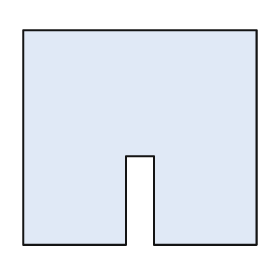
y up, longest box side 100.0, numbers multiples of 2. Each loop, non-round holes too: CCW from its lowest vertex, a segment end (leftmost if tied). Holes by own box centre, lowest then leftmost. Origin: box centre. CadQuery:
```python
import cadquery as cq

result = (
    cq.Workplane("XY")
    .moveTo(-50.0, -46.0)
    .lineTo(-6.0, -46.0)
    .lineTo(-6.0, -8.0)
    .lineTo(6.0, -8.0)
    .lineTo(6.0, -46.0)
    .lineTo(50.0, -46.0)
    .lineTo(50.0, 46.0)
    .lineTo(-50.0, 46.0)
    .close()
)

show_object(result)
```